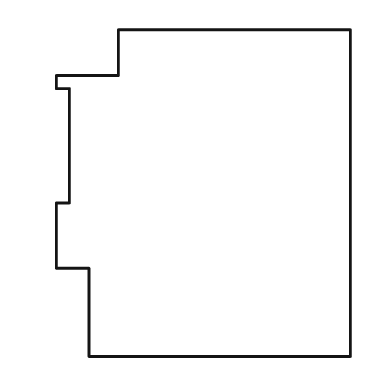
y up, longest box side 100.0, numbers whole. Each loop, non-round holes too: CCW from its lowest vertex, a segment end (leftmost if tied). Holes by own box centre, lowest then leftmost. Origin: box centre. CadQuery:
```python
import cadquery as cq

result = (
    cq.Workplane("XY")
    .moveTo(-35.0, -50.0)
    .lineTo(45.0, -50.0)
    .lineTo(45.0, 50.0)
    .lineTo(-26.0, 50.0)
    .lineTo(-26.0, 36.0)
    .lineTo(-45.0, 36.0)
    .lineTo(-45.0, 32.0)
    .lineTo(-41.0, 32.0)
    .lineTo(-41.0, -3.0)
    .lineTo(-45.0, -3.0)
    .lineTo(-45.0, -23.0)
    .lineTo(-35.0, -23.0)
    .close()
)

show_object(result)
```